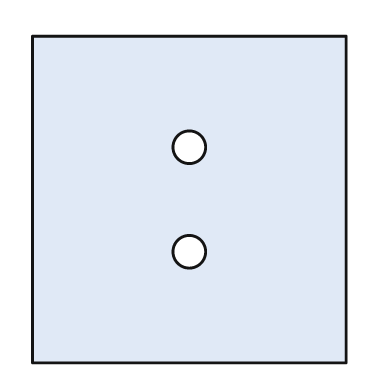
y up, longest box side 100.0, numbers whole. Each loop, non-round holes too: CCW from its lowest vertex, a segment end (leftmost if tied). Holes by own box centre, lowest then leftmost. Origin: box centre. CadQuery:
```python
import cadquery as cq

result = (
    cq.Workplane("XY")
    .moveTo(-48.0, -50.0)
    .lineTo(48.0, -50.0)
    .lineTo(48.0, 50.0)
    .lineTo(-48.0, 50.0)
    .close()
    .moveTo(0.0, -16.0)
    .circle(5.0)
    .moveTo(0.0, 16.0)
    .circle(5.0)
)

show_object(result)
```